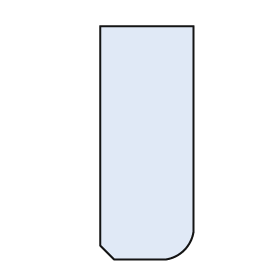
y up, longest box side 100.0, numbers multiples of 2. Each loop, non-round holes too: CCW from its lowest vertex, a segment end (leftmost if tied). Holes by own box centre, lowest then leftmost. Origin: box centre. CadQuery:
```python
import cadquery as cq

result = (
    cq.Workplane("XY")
    .moveTo(-14.0, -50.0)
    .lineTo(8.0, -50.0)
    .threePointArc((16.0, -46.0), (20.0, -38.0))
    .lineTo(20.0, 50.0)
    .lineTo(-20.0, 50.0)
    .lineTo(-20.0, -44.0)
    .close()
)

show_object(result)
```